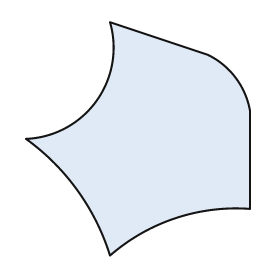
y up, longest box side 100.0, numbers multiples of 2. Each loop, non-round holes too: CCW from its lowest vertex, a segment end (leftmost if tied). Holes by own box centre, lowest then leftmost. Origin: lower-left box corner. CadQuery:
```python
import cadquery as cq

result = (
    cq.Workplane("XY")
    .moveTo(36.0, 0.0)
    .threePointArc((64.0, 16.0), (96.0, 20.0))
    .lineTo(96.0, 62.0)
    .threePointArc((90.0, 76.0), (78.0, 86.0))
    .lineTo(36.0, 100.0)
    .threePointArc((30.0, 66.0), (0.0, 50.0))
    .threePointArc((22.0, 28.0), (36.0, 0.0))
    .close()
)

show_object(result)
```